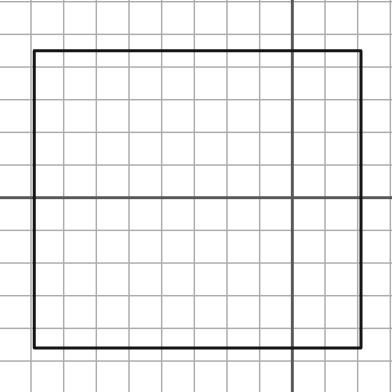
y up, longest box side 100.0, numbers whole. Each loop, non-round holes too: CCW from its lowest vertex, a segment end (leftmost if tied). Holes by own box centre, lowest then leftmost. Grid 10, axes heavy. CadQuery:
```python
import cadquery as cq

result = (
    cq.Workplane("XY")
    .moveTo(-79.0, -46.0)
    .lineTo(21.0, -46.0)
    .lineTo(21.0, 45.0)
    .lineTo(-79.0, 45.0)
    .close()
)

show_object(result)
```